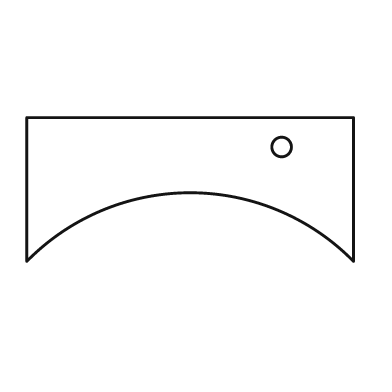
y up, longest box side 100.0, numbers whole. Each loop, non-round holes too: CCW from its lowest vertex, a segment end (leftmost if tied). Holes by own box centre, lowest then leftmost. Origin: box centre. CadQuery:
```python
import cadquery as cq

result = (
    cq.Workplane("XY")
    .moveTo(-50.0, -22.0)
    .threePointArc((0.0, -1.0), (50.0, -22.0))
    .lineTo(50.0, 22.0)
    .lineTo(-50.0, 22.0)
    .close()
    .moveTo(28.0, 13.0)
    .circle(3.0)
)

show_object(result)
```